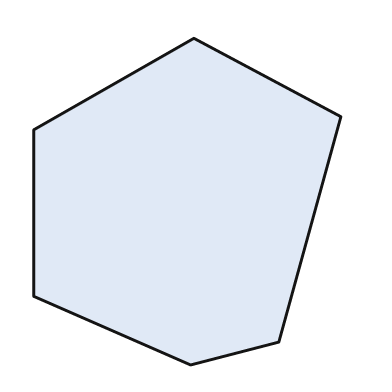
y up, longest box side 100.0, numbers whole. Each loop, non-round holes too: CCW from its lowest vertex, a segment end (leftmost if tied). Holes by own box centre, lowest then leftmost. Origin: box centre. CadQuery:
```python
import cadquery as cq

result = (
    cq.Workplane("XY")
    .moveTo(1.0, -50.0)
    .lineTo(28.0, -43.0)
    .lineTo(47.0, 26.0)
    .lineTo(2.0, 50.0)
    .lineTo(-47.0, 22.0)
    .lineTo(-47.0, -29.0)
    .close()
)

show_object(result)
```